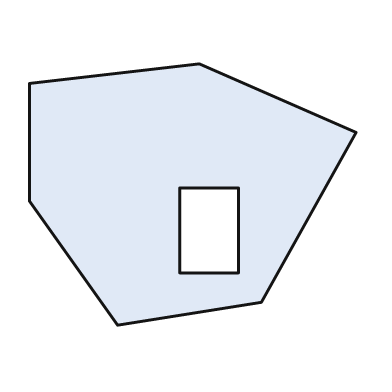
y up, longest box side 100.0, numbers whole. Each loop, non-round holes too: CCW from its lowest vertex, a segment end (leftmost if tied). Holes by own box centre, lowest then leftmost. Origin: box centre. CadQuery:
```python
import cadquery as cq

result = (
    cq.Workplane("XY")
    .moveTo(-23.0, -40.0)
    .lineTo(21.0, -33.0)
    .lineTo(50.0, 19.0)
    .lineTo(2.0, 40.0)
    .lineTo(-50.0, 34.0)
    .lineTo(-50.0, -2.0)
    .close()
    .moveTo(-4.0, -24.0)
    .lineTo(14.0, -24.0)
    .lineTo(14.0, 2.0)
    .lineTo(-4.0, 2.0)
    .close()
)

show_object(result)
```